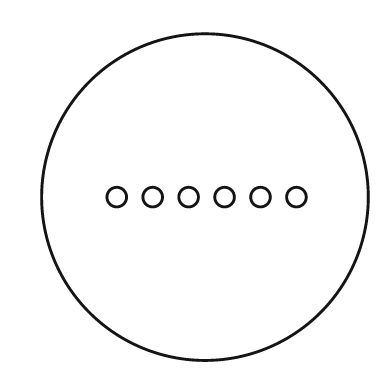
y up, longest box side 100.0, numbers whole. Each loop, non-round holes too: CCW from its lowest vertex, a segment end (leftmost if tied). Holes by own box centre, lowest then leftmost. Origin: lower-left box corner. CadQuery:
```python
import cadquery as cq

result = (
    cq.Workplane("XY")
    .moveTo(50.0, 50.0)
    .circle(50.0)
    .moveTo(23.0, 50.0)
    .circle(3.0)
    .moveTo(34.0, 50.0)
    .circle(3.0)
    .moveTo(45.0, 50.0)
    .circle(3.0)
    .moveTo(56.0, 50.0)
    .circle(3.0)
    .moveTo(67.0, 50.0)
    .circle(3.0)
    .moveTo(78.0, 50.0)
    .circle(3.0)
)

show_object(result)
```